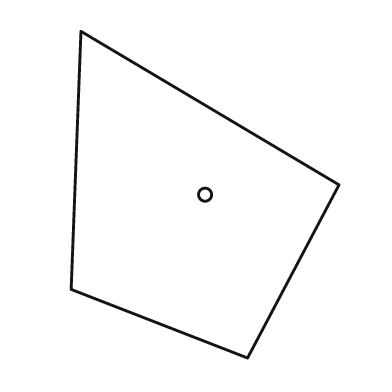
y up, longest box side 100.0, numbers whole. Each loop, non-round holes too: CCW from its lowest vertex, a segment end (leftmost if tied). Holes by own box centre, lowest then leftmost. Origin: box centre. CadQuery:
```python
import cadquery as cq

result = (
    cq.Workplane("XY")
    .moveTo(13.0, -50.0)
    .lineTo(41.0, 3.0)
    .lineTo(-38.0, 50.0)
    .lineTo(-41.0, -29.0)
    .close()
    .moveTo(0.0, 0.0)
    .circle(2.0)
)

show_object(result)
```